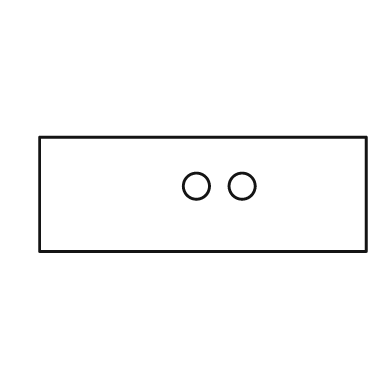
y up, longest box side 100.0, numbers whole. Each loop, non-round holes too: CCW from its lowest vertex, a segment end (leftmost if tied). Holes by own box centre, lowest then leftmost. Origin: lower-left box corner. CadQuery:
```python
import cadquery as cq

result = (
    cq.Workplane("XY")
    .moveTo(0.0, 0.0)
    .lineTo(100.0, 0.0)
    .lineTo(100.0, 35.0)
    .lineTo(0.0, 35.0)
    .close()
    .moveTo(48.0, 20.0)
    .circle(4.0)
    .moveTo(62.0, 20.0)
    .circle(4.0)
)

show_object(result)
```